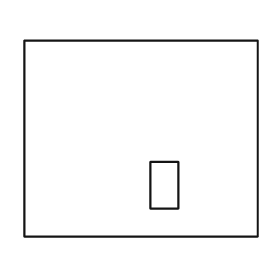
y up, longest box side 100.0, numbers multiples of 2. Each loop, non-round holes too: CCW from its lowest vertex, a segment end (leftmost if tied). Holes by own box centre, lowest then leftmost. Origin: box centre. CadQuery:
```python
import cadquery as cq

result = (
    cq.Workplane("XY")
    .moveTo(-50.0, -42.0)
    .lineTo(50.0, -42.0)
    .lineTo(50.0, 42.0)
    .lineTo(-50.0, 42.0)
    .close()
    .moveTo(4.0, -30.0)
    .lineTo(16.0, -30.0)
    .lineTo(16.0, -10.0)
    .lineTo(4.0, -10.0)
    .close()
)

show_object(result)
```